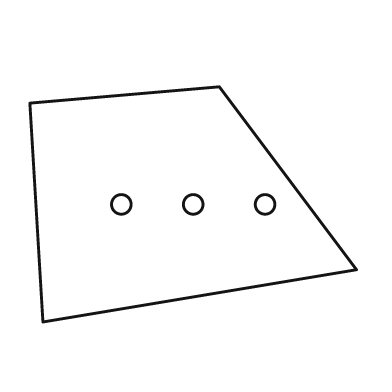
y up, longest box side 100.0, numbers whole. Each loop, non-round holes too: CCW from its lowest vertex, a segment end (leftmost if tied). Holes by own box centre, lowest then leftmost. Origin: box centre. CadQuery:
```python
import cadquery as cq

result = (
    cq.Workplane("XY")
    .moveTo(-46.0, -36.0)
    .lineTo(50.0, -20.0)
    .lineTo(8.0, 36.0)
    .lineTo(-50.0, 31.0)
    .close()
    .moveTo(-22.0, 0.0)
    .circle(3.0)
    .moveTo(0.0, 0.0)
    .circle(3.0)
    .moveTo(22.0, 0.0)
    .circle(3.0)
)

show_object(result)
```